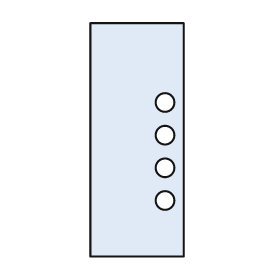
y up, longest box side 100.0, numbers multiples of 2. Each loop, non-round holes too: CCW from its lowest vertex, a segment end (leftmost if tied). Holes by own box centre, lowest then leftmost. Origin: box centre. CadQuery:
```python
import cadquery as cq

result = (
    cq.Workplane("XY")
    .moveTo(-20.0, -50.0)
    .lineTo(20.0, -50.0)
    .lineTo(20.0, 50.0)
    .lineTo(-20.0, 50.0)
    .close()
    .moveTo(12.0, -26.0)
    .circle(4.0)
    .moveTo(12.0, -12.0)
    .circle(4.0)
    .moveTo(12.0, 2.0)
    .circle(4.0)
    .moveTo(12.0, 16.0)
    .circle(4.0)
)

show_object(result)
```